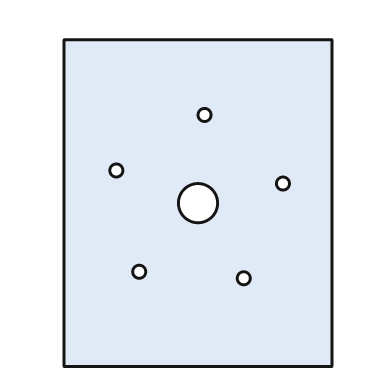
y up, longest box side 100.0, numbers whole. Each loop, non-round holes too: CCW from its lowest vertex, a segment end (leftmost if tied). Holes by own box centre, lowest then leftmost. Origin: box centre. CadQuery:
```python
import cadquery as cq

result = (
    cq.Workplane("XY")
    .moveTo(-41.0, -50.0)
    .lineTo(41.0, -50.0)
    .lineTo(41.0, 50.0)
    .lineTo(-41.0, 50.0)
    .close()
    .moveTo(14.0, -23.0)
    .circle(2.0)
    .moveTo(-18.0, -21.0)
    .circle(2.0)
    .moveTo(0.0, 0.0)
    .circle(6.0)
    .moveTo(26.0, 6.0)
    .circle(2.0)
    .moveTo(-25.0, 10.0)
    .circle(2.0)
    .moveTo(2.0, 27.0)
    .circle(2.0)
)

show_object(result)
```